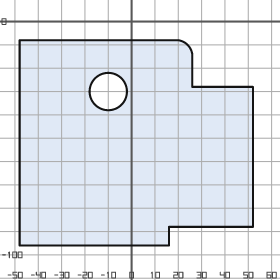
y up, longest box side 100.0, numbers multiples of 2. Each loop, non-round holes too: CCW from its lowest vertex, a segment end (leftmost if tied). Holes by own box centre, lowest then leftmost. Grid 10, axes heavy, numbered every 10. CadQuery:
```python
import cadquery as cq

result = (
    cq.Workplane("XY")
    .moveTo(-48.0, -96.0)
    .lineTo(16.0, -96.0)
    .lineTo(16.0, -88.0)
    .lineTo(52.0, -88.0)
    .lineTo(52.0, -28.0)
    .lineTo(26.0, -28.0)
    .lineTo(26.0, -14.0)
    .threePointArc((24.0, -10.0), (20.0, -8.0))
    .lineTo(-48.0, -8.0)
    .close()
    .moveTo(-10.0, -30.0)
    .circle(8.0)
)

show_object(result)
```